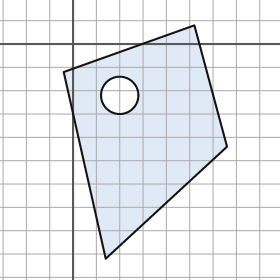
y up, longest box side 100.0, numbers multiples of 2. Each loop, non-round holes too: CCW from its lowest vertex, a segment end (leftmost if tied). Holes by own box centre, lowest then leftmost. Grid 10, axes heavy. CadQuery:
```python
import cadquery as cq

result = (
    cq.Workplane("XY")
    .moveTo(14.0, -92.0)
    .lineTo(66.0, -44.0)
    .lineTo(52.0, 8.0)
    .lineTo(-4.0, -12.0)
    .close()
    .moveTo(20.0, -22.0)
    .circle(8.0)
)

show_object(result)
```